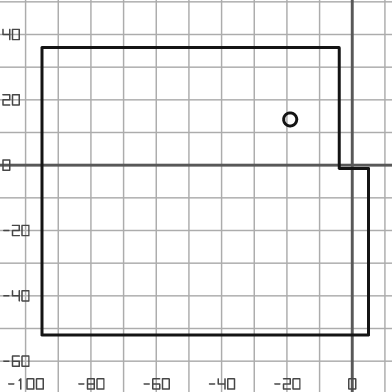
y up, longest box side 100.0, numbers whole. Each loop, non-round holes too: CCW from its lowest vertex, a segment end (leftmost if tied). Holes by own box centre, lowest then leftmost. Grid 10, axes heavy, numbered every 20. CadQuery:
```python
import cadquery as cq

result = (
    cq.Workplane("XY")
    .moveTo(-95.0, -52.0)
    .lineTo(5.0, -52.0)
    .lineTo(5.0, -1.0)
    .lineTo(-4.0, -1.0)
    .lineTo(-4.0, 36.0)
    .lineTo(-95.0, 36.0)
    .close()
    .moveTo(-19.0, 14.0)
    .circle(2.0)
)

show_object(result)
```